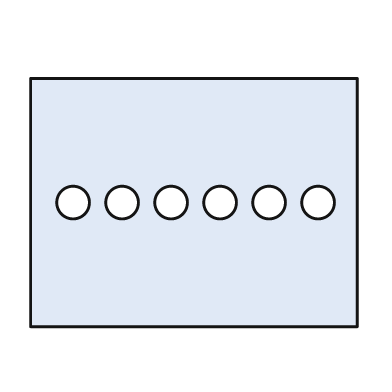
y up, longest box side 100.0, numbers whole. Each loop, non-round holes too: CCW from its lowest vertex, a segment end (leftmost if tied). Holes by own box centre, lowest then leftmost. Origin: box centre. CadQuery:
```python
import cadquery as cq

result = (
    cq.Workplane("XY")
    .moveTo(-50.0, -38.0)
    .lineTo(50.0, -38.0)
    .lineTo(50.0, 38.0)
    .lineTo(-50.0, 38.0)
    .close()
    .moveTo(-37.0, 0.0)
    .circle(5.0)
    .moveTo(-22.0, 0.0)
    .circle(5.0)
    .moveTo(-7.0, 0.0)
    .circle(5.0)
    .moveTo(8.0, 0.0)
    .circle(5.0)
    .moveTo(23.0, 0.0)
    .circle(5.0)
    .moveTo(38.0, 0.0)
    .circle(5.0)
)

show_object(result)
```